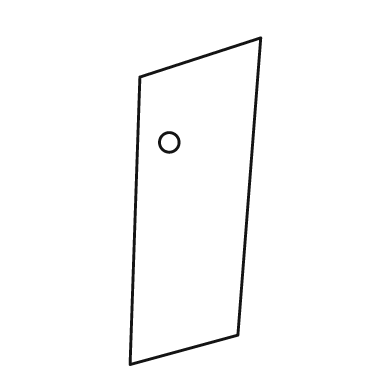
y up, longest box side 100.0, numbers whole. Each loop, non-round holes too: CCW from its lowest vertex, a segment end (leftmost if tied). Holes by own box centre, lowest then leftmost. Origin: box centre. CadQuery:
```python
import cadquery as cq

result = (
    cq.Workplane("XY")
    .moveTo(-20.0, -50.0)
    .lineTo(13.0, -41.0)
    .lineTo(20.0, 50.0)
    .lineTo(-17.0, 38.0)
    .close()
    .moveTo(-8.0, 18.0)
    .circle(3.0)
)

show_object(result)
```